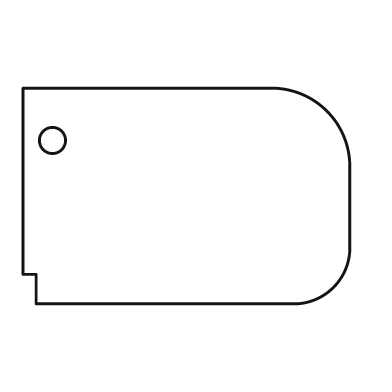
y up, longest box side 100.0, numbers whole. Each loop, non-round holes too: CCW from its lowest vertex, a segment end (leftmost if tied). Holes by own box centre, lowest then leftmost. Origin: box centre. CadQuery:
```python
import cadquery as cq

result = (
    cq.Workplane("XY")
    .moveTo(-46.0, -33.0)
    .lineTo(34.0, -33.0)
    .threePointArc((45.0, -28.0), (50.0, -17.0))
    .lineTo(50.0, 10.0)
    .threePointArc((43.0, 26.0), (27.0, 33.0))
    .lineTo(-50.0, 33.0)
    .lineTo(-50.0, -24.0)
    .lineTo(-46.0, -24.0)
    .close()
    .moveTo(-41.0, 17.0)
    .circle(4.0)
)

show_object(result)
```